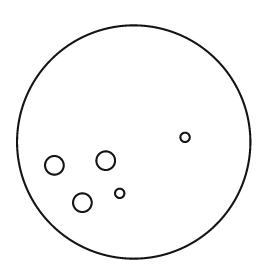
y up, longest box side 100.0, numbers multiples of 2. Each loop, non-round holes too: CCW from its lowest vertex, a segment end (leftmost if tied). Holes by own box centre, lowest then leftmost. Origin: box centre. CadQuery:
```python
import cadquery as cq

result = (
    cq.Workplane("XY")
    .moveTo(0.0, 0.0)
    .circle(50.0)
    .moveTo(-22.0, -26.0)
    .circle(4.0)
    .moveTo(-6.0, -22.0)
    .circle(2.0)
    .moveTo(-34.0, -10.0)
    .circle(4.0)
    .moveTo(-12.0, -8.0)
    .circle(4.0)
    .moveTo(22.0, 2.0)
    .circle(2.0)
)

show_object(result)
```